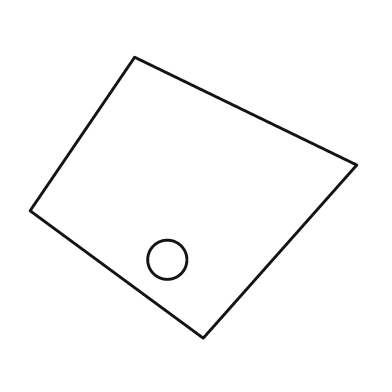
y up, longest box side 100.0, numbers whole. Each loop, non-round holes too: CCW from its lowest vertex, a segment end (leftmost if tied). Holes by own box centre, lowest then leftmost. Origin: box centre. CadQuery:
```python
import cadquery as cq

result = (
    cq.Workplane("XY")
    .moveTo(3.0, -43.0)
    .lineTo(50.0, 10.0)
    .lineTo(-18.0, 43.0)
    .lineTo(-50.0, -4.0)
    .close()
    .moveTo(-8.0, -19.0)
    .circle(6.0)
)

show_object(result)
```